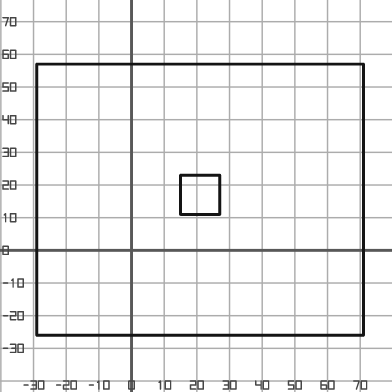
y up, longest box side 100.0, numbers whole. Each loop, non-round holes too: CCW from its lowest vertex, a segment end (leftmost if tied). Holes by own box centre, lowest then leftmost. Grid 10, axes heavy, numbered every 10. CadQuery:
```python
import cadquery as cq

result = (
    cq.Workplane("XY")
    .moveTo(-29.0, -26.0)
    .lineTo(71.0, -26.0)
    .lineTo(71.0, 57.0)
    .lineTo(-29.0, 57.0)
    .close()
    .moveTo(15.0, 11.0)
    .lineTo(27.0, 11.0)
    .lineTo(27.0, 23.0)
    .lineTo(15.0, 23.0)
    .close()
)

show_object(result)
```